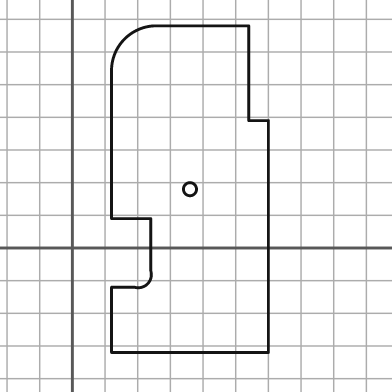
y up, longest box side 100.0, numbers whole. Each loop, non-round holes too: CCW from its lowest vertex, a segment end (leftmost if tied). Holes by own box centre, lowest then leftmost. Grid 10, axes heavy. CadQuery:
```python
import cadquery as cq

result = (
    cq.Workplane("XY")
    .moveTo(12.0, -32.0)
    .lineTo(60.0, -32.0)
    .lineTo(60.0, 39.0)
    .lineTo(54.0, 39.0)
    .lineTo(54.0, 68.0)
    .lineTo(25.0, 68.0)
    .threePointArc((16.0, 64.0), (12.0, 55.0))
    .lineTo(12.0, 9.0)
    .lineTo(24.0, 9.0)
    .lineTo(24.0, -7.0)
    .threePointArc((23.0, -11.0), (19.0, -12.0))
    .lineTo(12.0, -12.0)
    .close()
    .moveTo(36.0, 18.0)
    .circle(2.0)
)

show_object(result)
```